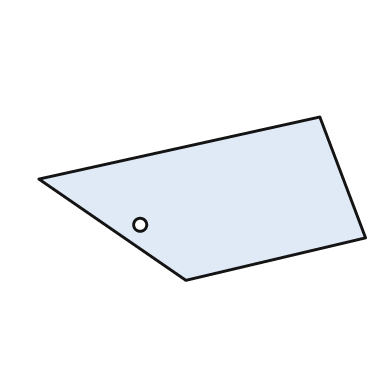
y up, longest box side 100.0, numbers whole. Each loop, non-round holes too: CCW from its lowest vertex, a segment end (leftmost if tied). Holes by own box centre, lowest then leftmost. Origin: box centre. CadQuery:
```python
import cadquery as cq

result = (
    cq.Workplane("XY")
    .moveTo(-5.0, -25.0)
    .lineTo(50.0, -12.0)
    .lineTo(36.0, 25.0)
    .lineTo(-50.0, 6.0)
    .close()
    .moveTo(-19.0, -8.0)
    .circle(2.0)
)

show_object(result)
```